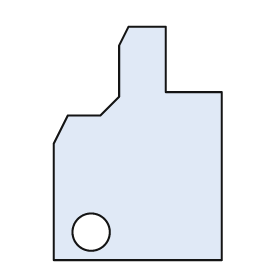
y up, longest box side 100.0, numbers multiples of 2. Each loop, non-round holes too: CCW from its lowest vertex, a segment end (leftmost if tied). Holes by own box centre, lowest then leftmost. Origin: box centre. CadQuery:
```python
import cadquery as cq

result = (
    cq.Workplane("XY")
    .moveTo(-36.0, -50.0)
    .lineTo(36.0, -50.0)
    .lineTo(36.0, 22.0)
    .lineTo(12.0, 22.0)
    .lineTo(12.0, 50.0)
    .lineTo(-4.0, 50.0)
    .lineTo(-8.0, 42.0)
    .lineTo(-8.0, 20.0)
    .lineTo(-16.0, 12.0)
    .lineTo(-30.0, 12.0)
    .lineTo(-36.0, 0.0)
    .close()
    .moveTo(-20.0, -38.0)
    .circle(8.0)
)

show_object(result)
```